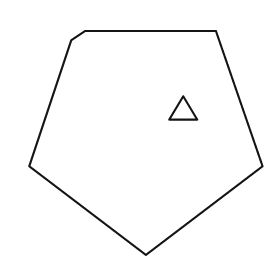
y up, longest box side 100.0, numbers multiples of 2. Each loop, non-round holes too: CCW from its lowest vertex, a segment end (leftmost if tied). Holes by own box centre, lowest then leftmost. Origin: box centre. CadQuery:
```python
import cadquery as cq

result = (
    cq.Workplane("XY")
    .moveTo(0.0, -48.0)
    .lineTo(50.0, -10.0)
    .lineTo(30.0, 48.0)
    .lineTo(-26.0, 48.0)
    .lineTo(-32.0, 44.0)
    .lineTo(-50.0, -10.0)
    .close()
    .moveTo(10.0, 10.0)
    .lineTo(22.0, 10.0)
    .lineTo(16.0, 20.0)
    .close()
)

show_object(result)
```